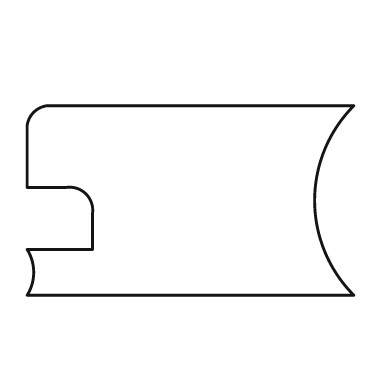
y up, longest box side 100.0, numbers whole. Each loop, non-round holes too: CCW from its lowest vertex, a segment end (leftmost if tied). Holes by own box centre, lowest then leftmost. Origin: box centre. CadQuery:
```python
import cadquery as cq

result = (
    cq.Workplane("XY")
    .moveTo(-50.0, -29.0)
    .lineTo(50.0, -29.0)
    .threePointArc((38.0, 0.0), (50.0, 29.0))
    .lineTo(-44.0, 29.0)
    .threePointArc((-48.0, 27.0), (-50.0, 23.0))
    .lineTo(-50.0, 4.0)
    .lineTo(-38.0, 4.0)
    .threePointArc((-32.0, 2.0), (-30.0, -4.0))
    .lineTo(-30.0, -15.0)
    .lineTo(-50.0, -15.0)
    .threePointArc((-48.0, -22.0), (-50.0, -29.0))
    .close()
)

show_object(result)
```